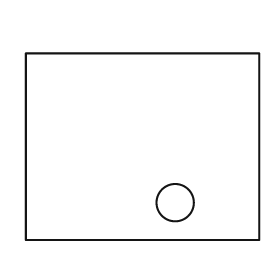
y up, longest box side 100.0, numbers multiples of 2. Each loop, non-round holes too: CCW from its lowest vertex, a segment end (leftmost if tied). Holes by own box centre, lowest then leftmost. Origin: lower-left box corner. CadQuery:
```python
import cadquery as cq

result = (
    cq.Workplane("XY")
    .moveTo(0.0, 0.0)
    .lineTo(100.0, 0.0)
    .lineTo(100.0, 80.0)
    .lineTo(0.0, 80.0)
    .close()
    .moveTo(64.0, 16.0)
    .circle(8.0)
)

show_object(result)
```